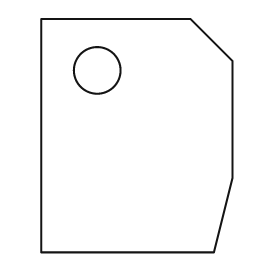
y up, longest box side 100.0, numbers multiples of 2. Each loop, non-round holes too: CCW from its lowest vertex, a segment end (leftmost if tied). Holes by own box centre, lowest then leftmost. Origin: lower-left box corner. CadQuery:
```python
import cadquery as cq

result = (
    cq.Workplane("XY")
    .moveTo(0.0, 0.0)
    .lineTo(74.0, 0.0)
    .lineTo(82.0, 32.0)
    .lineTo(82.0, 82.0)
    .lineTo(64.0, 100.0)
    .lineTo(0.0, 100.0)
    .close()
    .moveTo(24.0, 78.0)
    .circle(10.0)
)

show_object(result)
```